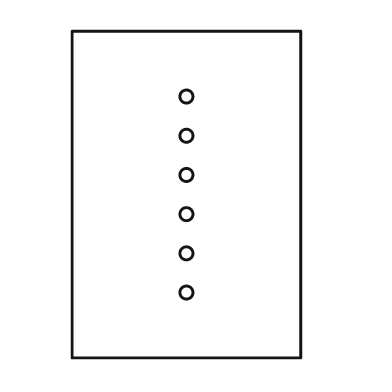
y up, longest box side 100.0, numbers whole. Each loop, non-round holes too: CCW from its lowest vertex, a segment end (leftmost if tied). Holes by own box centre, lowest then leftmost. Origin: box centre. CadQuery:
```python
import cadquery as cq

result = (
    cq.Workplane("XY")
    .moveTo(-35.0, -50.0)
    .lineTo(35.0, -50.0)
    .lineTo(35.0, 50.0)
    .lineTo(-35.0, 50.0)
    .close()
    .moveTo(0.0, -30.0)
    .circle(2.0)
    .moveTo(0.0, -18.0)
    .circle(2.0)
    .moveTo(0.0, -6.0)
    .circle(2.0)
    .moveTo(0.0, 6.0)
    .circle(2.0)
    .moveTo(0.0, 18.0)
    .circle(2.0)
    .moveTo(0.0, 30.0)
    .circle(2.0)
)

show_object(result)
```